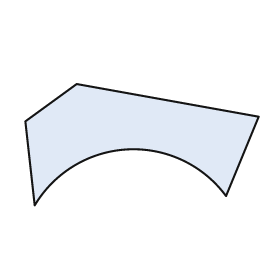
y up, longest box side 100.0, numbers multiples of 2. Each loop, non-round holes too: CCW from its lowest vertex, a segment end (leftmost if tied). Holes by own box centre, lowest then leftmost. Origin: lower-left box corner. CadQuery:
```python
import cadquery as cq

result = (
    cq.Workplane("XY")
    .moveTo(4.0, 0.0)
    .threePointArc((44.0, 24.0), (86.0, 4.0))
    .lineTo(100.0, 38.0)
    .lineTo(22.0, 52.0)
    .lineTo(0.0, 36.0)
    .close()
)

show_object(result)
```